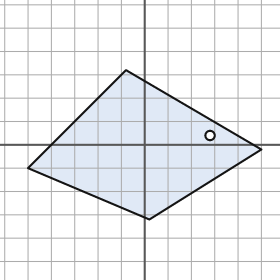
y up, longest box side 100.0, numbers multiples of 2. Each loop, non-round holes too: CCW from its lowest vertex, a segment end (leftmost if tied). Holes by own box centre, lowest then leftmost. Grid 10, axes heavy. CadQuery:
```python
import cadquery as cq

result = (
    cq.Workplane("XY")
    .moveTo(2.0, -32.0)
    .lineTo(50.0, -2.0)
    .lineTo(-8.0, 32.0)
    .lineTo(-50.0, -10.0)
    .close()
    .moveTo(28.0, 4.0)
    .circle(2.0)
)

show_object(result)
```